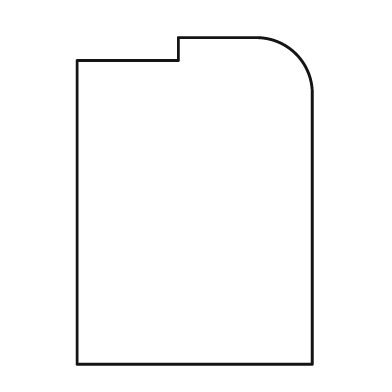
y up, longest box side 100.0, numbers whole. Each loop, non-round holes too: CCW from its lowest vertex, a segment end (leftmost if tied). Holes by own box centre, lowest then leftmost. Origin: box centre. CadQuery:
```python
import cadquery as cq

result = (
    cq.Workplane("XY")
    .moveTo(-36.0, -50.0)
    .lineTo(36.0, -50.0)
    .lineTo(36.0, 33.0)
    .threePointArc((31.0, 45.0), (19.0, 50.0))
    .lineTo(-5.0, 50.0)
    .lineTo(-5.0, 43.0)
    .lineTo(-36.0, 43.0)
    .close()
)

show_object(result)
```